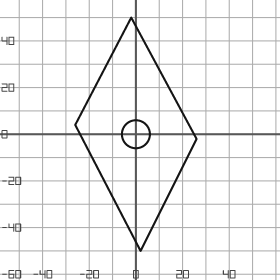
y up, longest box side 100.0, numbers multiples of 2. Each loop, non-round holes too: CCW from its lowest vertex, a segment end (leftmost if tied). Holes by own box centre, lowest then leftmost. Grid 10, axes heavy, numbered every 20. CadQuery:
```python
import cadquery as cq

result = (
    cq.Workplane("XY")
    .moveTo(2.0, -50.0)
    .lineTo(26.0, -2.0)
    .lineTo(-2.0, 50.0)
    .lineTo(-26.0, 4.0)
    .close()
    .moveTo(0.0, 0.0)
    .circle(6.0)
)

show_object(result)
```